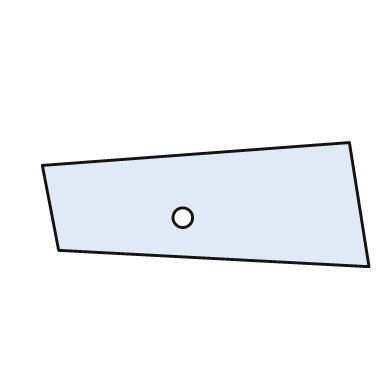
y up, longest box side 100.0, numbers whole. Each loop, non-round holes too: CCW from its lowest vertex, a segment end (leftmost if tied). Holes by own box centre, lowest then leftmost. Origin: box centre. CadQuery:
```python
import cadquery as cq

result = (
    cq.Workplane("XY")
    .moveTo(50.0, -19.0)
    .lineTo(44.0, 19.0)
    .lineTo(-50.0, 12.0)
    .lineTo(-45.0, -14.0)
    .close()
    .moveTo(-7.0, -4.0)
    .circle(3.0)
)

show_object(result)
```